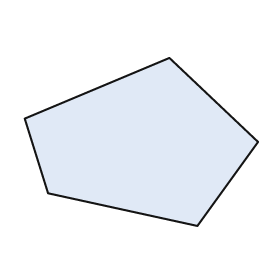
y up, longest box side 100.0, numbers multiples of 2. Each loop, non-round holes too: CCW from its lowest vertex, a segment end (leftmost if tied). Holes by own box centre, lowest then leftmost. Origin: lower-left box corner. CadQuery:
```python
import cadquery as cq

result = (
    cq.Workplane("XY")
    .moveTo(74.0, 0.0)
    .lineTo(100.0, 36.0)
    .lineTo(62.0, 72.0)
    .lineTo(0.0, 46.0)
    .lineTo(10.0, 14.0)
    .close()
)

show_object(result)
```